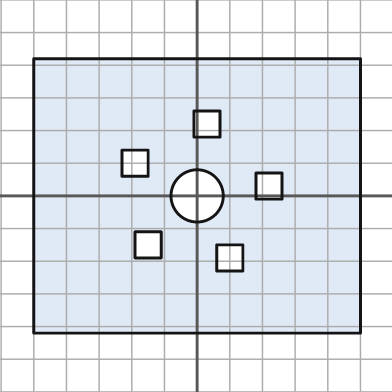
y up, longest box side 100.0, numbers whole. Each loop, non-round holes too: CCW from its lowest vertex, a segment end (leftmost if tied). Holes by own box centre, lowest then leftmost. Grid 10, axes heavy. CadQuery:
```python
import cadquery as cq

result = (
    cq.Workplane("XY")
    .moveTo(-50.0, -42.0)
    .lineTo(50.0, -42.0)
    .lineTo(50.0, 42.0)
    .lineTo(-50.0, 42.0)
    .close()
    .moveTo(6.0, -23.0)
    .lineTo(14.0, -23.0)
    .lineTo(14.0, -15.0)
    .lineTo(6.0, -15.0)
    .close()
    .moveTo(-19.0, -19.0)
    .lineTo(-11.0, -19.0)
    .lineTo(-11.0, -11.0)
    .lineTo(-19.0, -11.0)
    .close()
    .moveTo(0.0, 0.0)
    .circle(8.0)
    .moveTo(18.0, -1.0)
    .lineTo(26.0, -1.0)
    .lineTo(26.0, 7.0)
    .lineTo(18.0, 7.0)
    .close()
    .moveTo(-23.0, 6.0)
    .lineTo(-15.0, 6.0)
    .lineTo(-15.0, 14.0)
    .lineTo(-23.0, 14.0)
    .close()
    .moveTo(-1.0, 18.0)
    .lineTo(7.0, 18.0)
    .lineTo(7.0, 26.0)
    .lineTo(-1.0, 26.0)
    .close()
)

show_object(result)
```